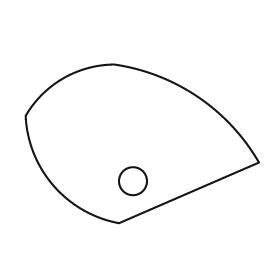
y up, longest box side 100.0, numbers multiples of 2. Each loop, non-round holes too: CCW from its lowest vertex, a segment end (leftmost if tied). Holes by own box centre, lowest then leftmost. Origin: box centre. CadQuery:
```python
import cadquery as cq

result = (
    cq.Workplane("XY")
    .moveTo(-10.0, -34.0)
    .lineTo(50.0, -8.0)
    .threePointArc((24.0, 20.0), (-12.0, 34.0))
    .threePointArc((-34.0, 28.0), (-50.0, 12.0))
    .threePointArc((-38.0, -18.0), (-10.0, -34.0))
    .close()
    .moveTo(-4.0, -16.0)
    .circle(6.0)
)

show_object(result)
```